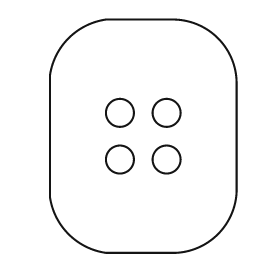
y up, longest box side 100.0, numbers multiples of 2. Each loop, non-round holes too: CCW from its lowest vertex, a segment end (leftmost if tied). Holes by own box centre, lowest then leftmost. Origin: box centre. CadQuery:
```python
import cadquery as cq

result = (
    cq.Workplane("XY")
    .moveTo(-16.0, -50.0)
    .lineTo(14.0, -50.0)
    .threePointArc((32.0, -42.0), (40.0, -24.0))
    .lineTo(40.0, 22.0)
    .threePointArc((32.0, 42.0), (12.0, 50.0))
    .lineTo(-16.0, 50.0)
    .threePointArc((-32.0, 42.0), (-40.0, 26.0))
    .lineTo(-40.0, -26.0)
    .threePointArc((-32.0, -42.0), (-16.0, -50.0))
    .close()
    .moveTo(-10.0, -10.0)
    .circle(6.0)
    .moveTo(10.0, -10.0)
    .circle(6.0)
    .moveTo(-10.0, 10.0)
    .circle(6.0)
    .moveTo(10.0, 10.0)
    .circle(6.0)
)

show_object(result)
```